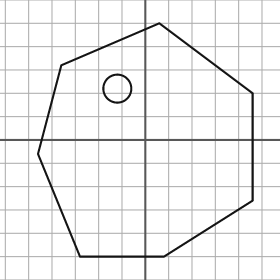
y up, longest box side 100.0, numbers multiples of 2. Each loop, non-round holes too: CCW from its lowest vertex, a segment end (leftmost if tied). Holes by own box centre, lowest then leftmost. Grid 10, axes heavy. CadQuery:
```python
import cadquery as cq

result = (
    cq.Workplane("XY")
    .moveTo(-28.0, -50.0)
    .lineTo(8.0, -50.0)
    .lineTo(46.0, -26.0)
    .lineTo(46.0, 20.0)
    .lineTo(6.0, 50.0)
    .lineTo(-36.0, 32.0)
    .lineTo(-46.0, -6.0)
    .close()
    .moveTo(-12.0, 22.0)
    .circle(6.0)
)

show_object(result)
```